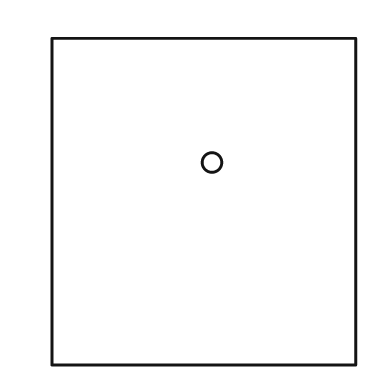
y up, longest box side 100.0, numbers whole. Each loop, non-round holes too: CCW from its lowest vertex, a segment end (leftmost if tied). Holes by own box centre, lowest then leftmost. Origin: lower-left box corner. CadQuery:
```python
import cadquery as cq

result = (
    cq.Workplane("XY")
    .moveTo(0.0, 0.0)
    .lineTo(93.0, 0.0)
    .lineTo(93.0, 100.0)
    .lineTo(0.0, 100.0)
    .close()
    .moveTo(49.0, 62.0)
    .circle(3.0)
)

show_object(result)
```